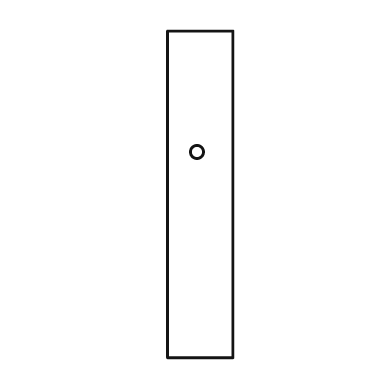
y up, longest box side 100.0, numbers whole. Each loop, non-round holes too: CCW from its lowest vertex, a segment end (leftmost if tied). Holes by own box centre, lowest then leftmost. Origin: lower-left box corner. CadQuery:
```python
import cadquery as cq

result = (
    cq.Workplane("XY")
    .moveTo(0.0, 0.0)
    .lineTo(20.0, 0.0)
    .lineTo(20.0, 100.0)
    .lineTo(0.0, 100.0)
    .close()
    .moveTo(9.0, 63.0)
    .circle(2.0)
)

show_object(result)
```